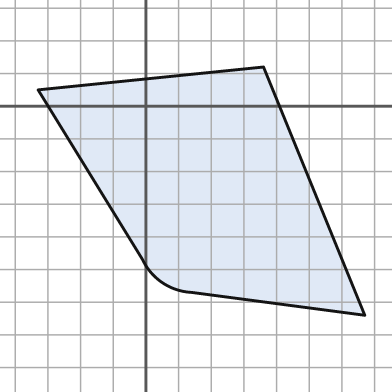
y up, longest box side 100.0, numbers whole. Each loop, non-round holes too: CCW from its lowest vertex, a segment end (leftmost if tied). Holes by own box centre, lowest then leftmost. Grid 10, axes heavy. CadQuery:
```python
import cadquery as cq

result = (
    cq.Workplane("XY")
    .moveTo(67.0, -64.0)
    .lineTo(36.0, 12.0)
    .lineTo(-33.0, 5.0)
    .lineTo(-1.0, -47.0)
    .threePointArc((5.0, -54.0), (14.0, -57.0))
    .close()
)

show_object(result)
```